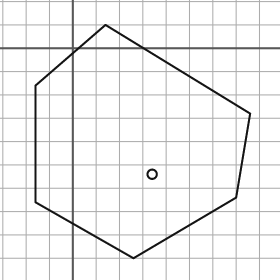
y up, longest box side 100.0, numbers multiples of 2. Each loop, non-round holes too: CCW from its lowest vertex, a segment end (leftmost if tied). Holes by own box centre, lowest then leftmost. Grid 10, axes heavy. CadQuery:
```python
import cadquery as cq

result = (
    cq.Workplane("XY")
    .moveTo(26.0, -90.0)
    .lineTo(70.0, -64.0)
    .lineTo(76.0, -28.0)
    .lineTo(14.0, 10.0)
    .lineTo(-16.0, -16.0)
    .lineTo(-16.0, -66.0)
    .close()
    .moveTo(34.0, -54.0)
    .circle(2.0)
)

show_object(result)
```